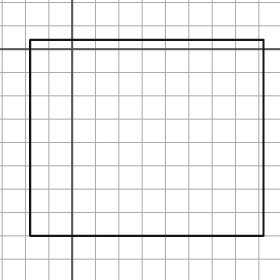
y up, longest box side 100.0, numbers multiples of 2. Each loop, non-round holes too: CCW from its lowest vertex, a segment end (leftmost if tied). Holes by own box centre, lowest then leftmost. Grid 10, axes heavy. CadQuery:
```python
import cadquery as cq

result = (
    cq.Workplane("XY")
    .moveTo(-18.0, -80.0)
    .lineTo(82.0, -80.0)
    .lineTo(82.0, 4.0)
    .lineTo(-18.0, 4.0)
    .close()
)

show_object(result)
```